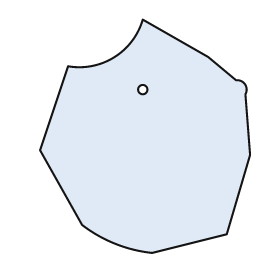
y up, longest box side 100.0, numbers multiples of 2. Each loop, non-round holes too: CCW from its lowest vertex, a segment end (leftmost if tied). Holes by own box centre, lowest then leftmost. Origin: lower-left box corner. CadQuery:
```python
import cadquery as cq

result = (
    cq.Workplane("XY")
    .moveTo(48.0, 0.0)
    .lineTo(80.0, 8.0)
    .lineTo(90.0, 42.0)
    .lineTo(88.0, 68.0)
    .threePointArc((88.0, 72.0), (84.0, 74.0))
    .lineTo(72.0, 84.0)
    .lineTo(44.0, 100.0)
    .threePointArc((32.0, 84.0), (12.0, 80.0))
    .lineTo(0.0, 44.0)
    .lineTo(18.0, 12.0)
    .threePointArc((32.0, 4.0), (48.0, 0.0))
    .close()
    .moveTo(44.0, 70.0)
    .circle(2.0)
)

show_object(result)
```